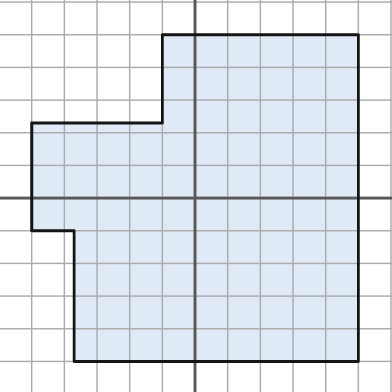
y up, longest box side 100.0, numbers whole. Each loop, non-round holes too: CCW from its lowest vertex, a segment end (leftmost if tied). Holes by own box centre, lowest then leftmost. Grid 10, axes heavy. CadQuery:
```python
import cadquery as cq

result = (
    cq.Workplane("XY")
    .moveTo(-37.0, -50.0)
    .lineTo(50.0, -50.0)
    .lineTo(50.0, 50.0)
    .lineTo(-10.0, 50.0)
    .lineTo(-10.0, 23.0)
    .lineTo(-50.0, 23.0)
    .lineTo(-50.0, -10.0)
    .lineTo(-37.0, -10.0)
    .close()
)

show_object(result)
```